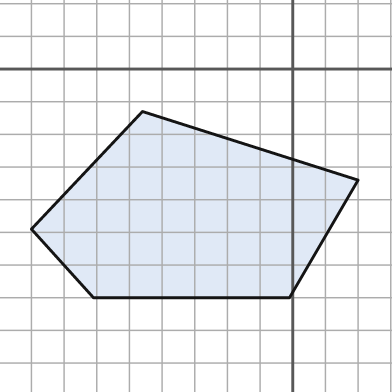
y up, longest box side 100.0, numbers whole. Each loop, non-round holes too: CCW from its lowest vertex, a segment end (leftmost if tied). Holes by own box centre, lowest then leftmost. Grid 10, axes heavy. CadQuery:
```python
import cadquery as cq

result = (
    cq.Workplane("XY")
    .moveTo(-61.0, -70.0)
    .lineTo(-1.0, -70.0)
    .lineTo(20.0, -34.0)
    .lineTo(-46.0, -13.0)
    .lineTo(-80.0, -49.0)
    .close()
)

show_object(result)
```